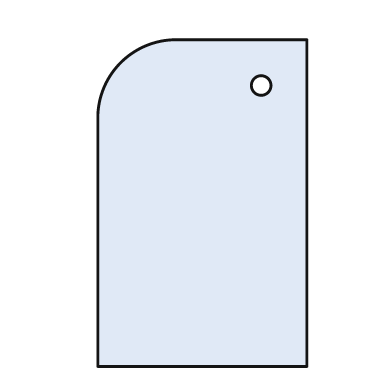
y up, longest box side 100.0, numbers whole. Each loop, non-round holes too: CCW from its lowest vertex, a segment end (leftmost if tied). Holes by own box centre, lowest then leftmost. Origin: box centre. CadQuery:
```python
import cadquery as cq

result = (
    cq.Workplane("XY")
    .moveTo(-32.0, -50.0)
    .lineTo(32.0, -50.0)
    .lineTo(32.0, 50.0)
    .lineTo(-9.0, 50.0)
    .threePointArc((-25.0, 43.0), (-32.0, 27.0))
    .close()
    .moveTo(18.0, 36.0)
    .circle(3.0)
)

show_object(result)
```